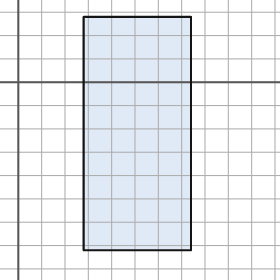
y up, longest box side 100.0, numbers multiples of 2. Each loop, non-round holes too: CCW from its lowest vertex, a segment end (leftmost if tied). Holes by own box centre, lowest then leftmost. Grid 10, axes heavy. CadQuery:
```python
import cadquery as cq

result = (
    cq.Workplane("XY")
    .moveTo(28.0, -72.0)
    .lineTo(74.0, -72.0)
    .lineTo(74.0, 28.0)
    .lineTo(28.0, 28.0)
    .close()
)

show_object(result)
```